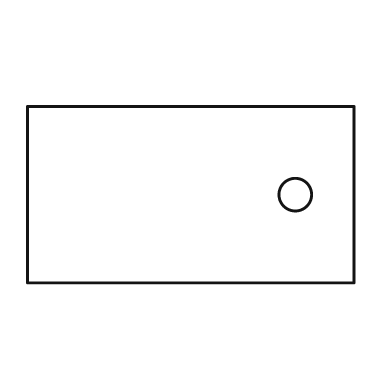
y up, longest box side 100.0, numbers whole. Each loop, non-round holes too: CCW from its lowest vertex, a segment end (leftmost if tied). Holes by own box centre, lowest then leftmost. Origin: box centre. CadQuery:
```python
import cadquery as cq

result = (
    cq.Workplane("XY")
    .moveTo(-50.0, -27.0)
    .lineTo(50.0, -27.0)
    .lineTo(50.0, 27.0)
    .lineTo(-50.0, 27.0)
    .close()
    .moveTo(32.0, 0.0)
    .circle(5.0)
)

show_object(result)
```